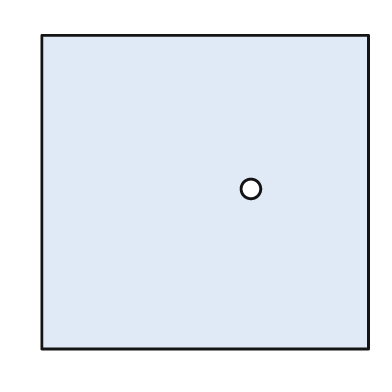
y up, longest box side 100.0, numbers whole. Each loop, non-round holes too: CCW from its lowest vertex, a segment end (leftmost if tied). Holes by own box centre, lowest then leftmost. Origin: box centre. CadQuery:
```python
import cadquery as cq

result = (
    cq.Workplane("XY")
    .moveTo(-50.0, -48.0)
    .lineTo(50.0, -48.0)
    .lineTo(50.0, 48.0)
    .lineTo(-50.0, 48.0)
    .close()
    .moveTo(14.0, 1.0)
    .circle(3.0)
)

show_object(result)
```